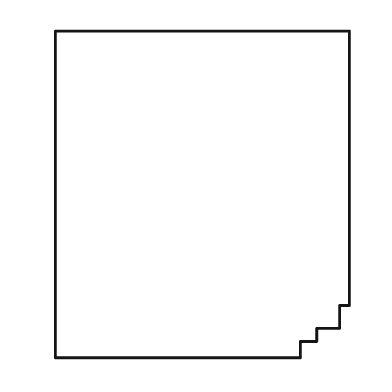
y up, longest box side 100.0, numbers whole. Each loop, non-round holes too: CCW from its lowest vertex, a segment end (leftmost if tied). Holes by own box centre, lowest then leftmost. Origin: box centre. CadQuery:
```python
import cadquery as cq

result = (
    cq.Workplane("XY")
    .moveTo(-45.0, -50.0)
    .lineTo(30.0, -50.0)
    .lineTo(30.0, -45.0)
    .lineTo(35.0, -45.0)
    .lineTo(35.0, -41.0)
    .lineTo(42.0, -41.0)
    .lineTo(42.0, -34.0)
    .lineTo(45.0, -34.0)
    .lineTo(45.0, 50.0)
    .lineTo(-45.0, 50.0)
    .close()
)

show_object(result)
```